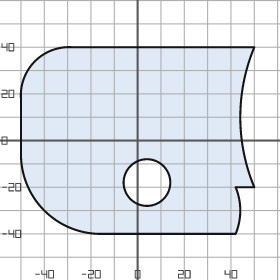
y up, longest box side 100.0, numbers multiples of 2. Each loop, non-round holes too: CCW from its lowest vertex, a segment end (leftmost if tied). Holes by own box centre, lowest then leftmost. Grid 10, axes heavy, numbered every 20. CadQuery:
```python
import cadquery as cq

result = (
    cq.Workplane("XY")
    .moveTo(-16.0, -40.0)
    .lineTo(42.0, -40.0)
    .threePointArc((44.0, -30.0), (42.0, -20.0))
    .lineTo(50.0, -20.0)
    .threePointArc((44.0, 10.0), (50.0, 40.0))
    .lineTo(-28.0, 40.0)
    .threePointArc((-44.0, 34.0), (-50.0, 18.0))
    .lineTo(-50.0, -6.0)
    .threePointArc((-40.0, -30.0), (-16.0, -40.0))
    .close()
    .moveTo(4.0, -18.0)
    .circle(10.0)
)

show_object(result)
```